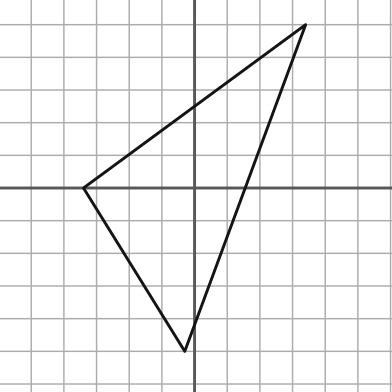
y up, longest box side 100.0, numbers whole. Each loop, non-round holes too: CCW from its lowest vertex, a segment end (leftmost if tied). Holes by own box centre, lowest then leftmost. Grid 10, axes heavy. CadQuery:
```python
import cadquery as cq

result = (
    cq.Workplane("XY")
    .moveTo(-3.0, -50.0)
    .lineTo(34.0, 50.0)
    .lineTo(-34.0, 0.0)
    .close()
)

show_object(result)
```